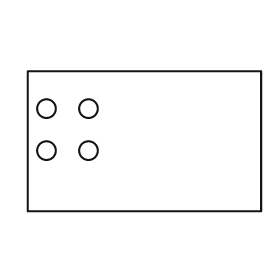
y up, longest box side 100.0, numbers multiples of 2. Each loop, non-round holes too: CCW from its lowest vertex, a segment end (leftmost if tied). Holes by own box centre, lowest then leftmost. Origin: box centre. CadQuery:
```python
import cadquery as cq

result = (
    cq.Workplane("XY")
    .moveTo(-50.0, -30.0)
    .lineTo(50.0, -30.0)
    .lineTo(50.0, 30.0)
    .lineTo(-50.0, 30.0)
    .close()
    .moveTo(-42.0, -4.0)
    .circle(4.0)
    .moveTo(-24.0, -4.0)
    .circle(4.0)
    .moveTo(-42.0, 14.0)
    .circle(4.0)
    .moveTo(-24.0, 14.0)
    .circle(4.0)
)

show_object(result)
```